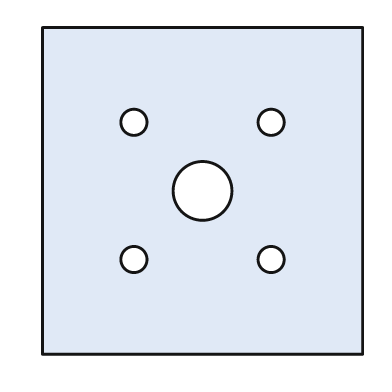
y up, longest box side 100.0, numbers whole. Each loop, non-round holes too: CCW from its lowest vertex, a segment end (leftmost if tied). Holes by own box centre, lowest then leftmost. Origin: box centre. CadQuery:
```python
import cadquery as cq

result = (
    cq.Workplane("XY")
    .moveTo(-49.0, -50.0)
    .lineTo(49.0, -50.0)
    .lineTo(49.0, 50.0)
    .lineTo(-49.0, 50.0)
    .close()
    .moveTo(-21.0, -21.0)
    .circle(4.0)
    .moveTo(21.0, -21.0)
    .circle(4.0)
    .moveTo(0.0, 0.0)
    .circle(9.0)
    .moveTo(-21.0, 21.0)
    .circle(4.0)
    .moveTo(21.0, 21.0)
    .circle(4.0)
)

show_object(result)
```